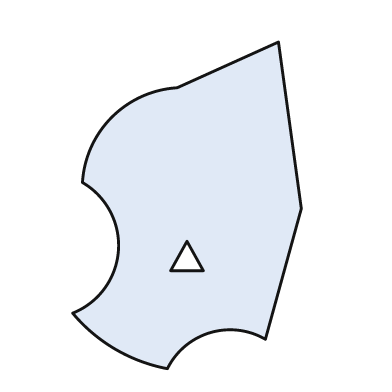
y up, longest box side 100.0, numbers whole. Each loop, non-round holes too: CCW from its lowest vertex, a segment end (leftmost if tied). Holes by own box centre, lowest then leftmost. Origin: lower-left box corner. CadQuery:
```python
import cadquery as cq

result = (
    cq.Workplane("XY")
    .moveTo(29.0, 0.0)
    .threePointArc((42.0, 11.0), (59.0, 9.0))
    .lineTo(70.0, 49.0)
    .lineTo(63.0, 100.0)
    .lineTo(32.0, 86.0)
    .threePointArc((12.0, 77.0), (3.0, 57.0))
    .threePointArc((14.0, 36.0), (0.0, 17.0))
    .threePointArc((13.0, 6.0), (29.0, 0.0))
    .close()
    .moveTo(30.0, 30.0)
    .lineTo(40.0, 30.0)
    .lineTo(35.0, 39.0)
    .close()
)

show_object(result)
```